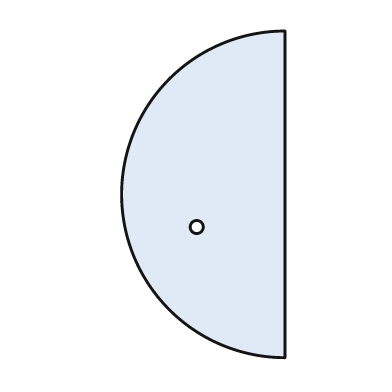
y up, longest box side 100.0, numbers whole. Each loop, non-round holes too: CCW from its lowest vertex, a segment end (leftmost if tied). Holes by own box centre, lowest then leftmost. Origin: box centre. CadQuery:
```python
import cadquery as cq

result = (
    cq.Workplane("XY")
    .moveTo(25.0, -50.0)
    .lineTo(25.0, 50.0)
    .threePointArc((-25.0, 0.0), (25.0, -50.0))
    .close()
    .moveTo(-2.0, -10.0)
    .circle(2.0)
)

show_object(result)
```